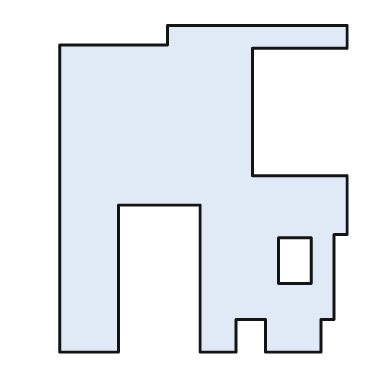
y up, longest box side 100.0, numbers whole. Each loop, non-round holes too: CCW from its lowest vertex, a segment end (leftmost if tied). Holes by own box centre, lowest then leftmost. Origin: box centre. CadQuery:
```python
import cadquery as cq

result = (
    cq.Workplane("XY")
    .moveTo(-44.0, -50.0)
    .lineTo(-26.0, -50.0)
    .lineTo(-26.0, -5.0)
    .lineTo(-1.0, -5.0)
    .lineTo(-1.0, -50.0)
    .lineTo(10.0, -50.0)
    .lineTo(10.0, -40.0)
    .lineTo(19.0, -40.0)
    .lineTo(19.0, -50.0)
    .lineTo(36.0, -50.0)
    .lineTo(36.0, -40.0)
    .lineTo(40.0, -40.0)
    .lineTo(40.0, -14.0)
    .lineTo(44.0, -14.0)
    .lineTo(44.0, 4.0)
    .lineTo(15.0, 4.0)
    .lineTo(15.0, 43.0)
    .lineTo(44.0, 43.0)
    .lineTo(44.0, 50.0)
    .lineTo(-11.0, 50.0)
    .lineTo(-11.0, 44.0)
    .lineTo(-44.0, 44.0)
    .close()
    .moveTo(23.0, -29.0)
    .lineTo(33.0, -29.0)
    .lineTo(33.0, -15.0)
    .lineTo(23.0, -15.0)
    .close()
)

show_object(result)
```